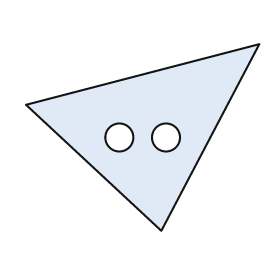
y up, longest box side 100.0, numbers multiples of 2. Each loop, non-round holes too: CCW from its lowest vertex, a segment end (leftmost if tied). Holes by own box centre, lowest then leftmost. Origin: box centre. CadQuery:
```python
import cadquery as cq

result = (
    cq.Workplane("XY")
    .moveTo(8.0, -40.0)
    .lineTo(50.0, 40.0)
    .lineTo(-50.0, 14.0)
    .close()
    .moveTo(-10.0, 0.0)
    .circle(6.0)
    .moveTo(10.0, 0.0)
    .circle(6.0)
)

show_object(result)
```